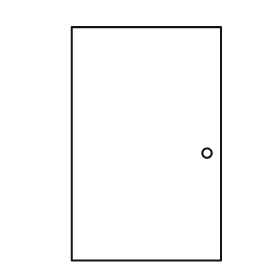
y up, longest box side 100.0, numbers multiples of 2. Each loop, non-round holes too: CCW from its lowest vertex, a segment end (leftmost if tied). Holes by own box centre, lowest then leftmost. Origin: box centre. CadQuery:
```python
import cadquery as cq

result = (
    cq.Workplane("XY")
    .moveTo(-32.0, -50.0)
    .lineTo(32.0, -50.0)
    .lineTo(32.0, 50.0)
    .lineTo(-32.0, 50.0)
    .close()
    .moveTo(26.0, -4.0)
    .circle(2.0)
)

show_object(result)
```